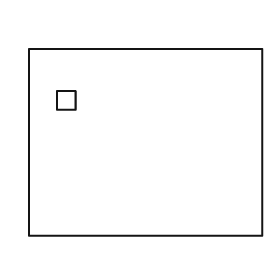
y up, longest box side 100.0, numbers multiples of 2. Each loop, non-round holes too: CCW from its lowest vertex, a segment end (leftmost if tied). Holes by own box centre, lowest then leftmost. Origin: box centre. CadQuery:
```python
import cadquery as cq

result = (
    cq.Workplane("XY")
    .moveTo(-50.0, -40.0)
    .lineTo(50.0, -40.0)
    .lineTo(50.0, 40.0)
    .lineTo(-50.0, 40.0)
    .close()
    .moveTo(-38.0, 14.0)
    .lineTo(-30.0, 14.0)
    .lineTo(-30.0, 22.0)
    .lineTo(-38.0, 22.0)
    .close()
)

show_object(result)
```